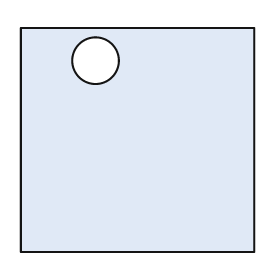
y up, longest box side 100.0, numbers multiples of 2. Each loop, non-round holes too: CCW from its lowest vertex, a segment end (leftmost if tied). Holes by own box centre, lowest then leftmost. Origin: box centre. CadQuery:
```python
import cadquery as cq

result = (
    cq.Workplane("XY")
    .moveTo(-50.0, -48.0)
    .lineTo(50.0, -48.0)
    .lineTo(50.0, 48.0)
    .lineTo(-50.0, 48.0)
    .close()
    .moveTo(-18.0, 34.0)
    .circle(10.0)
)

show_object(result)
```